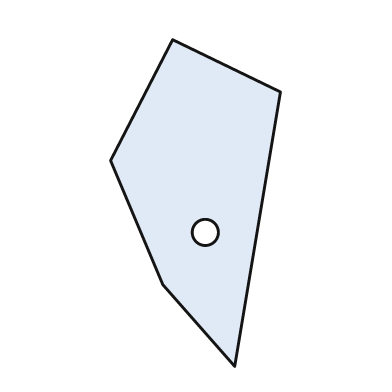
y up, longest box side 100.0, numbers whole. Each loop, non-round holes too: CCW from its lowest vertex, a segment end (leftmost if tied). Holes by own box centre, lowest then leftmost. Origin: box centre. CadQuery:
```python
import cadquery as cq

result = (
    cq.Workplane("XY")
    .moveTo(12.0, -50.0)
    .lineTo(26.0, 34.0)
    .lineTo(-7.0, 50.0)
    .lineTo(-26.0, 13.0)
    .lineTo(-10.0, -25.0)
    .close()
    .moveTo(3.0, -9.0)
    .circle(4.0)
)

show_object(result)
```